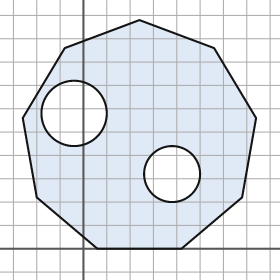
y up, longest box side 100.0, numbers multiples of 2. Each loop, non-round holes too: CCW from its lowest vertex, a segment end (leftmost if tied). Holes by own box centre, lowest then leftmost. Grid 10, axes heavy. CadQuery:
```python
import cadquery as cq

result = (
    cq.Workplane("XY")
    .moveTo(6.0, 0.0)
    .lineTo(42.0, 0.0)
    .lineTo(68.0, 22.0)
    .lineTo(74.0, 56.0)
    .lineTo(56.0, 86.0)
    .lineTo(24.0, 98.0)
    .lineTo(-8.0, 86.0)
    .lineTo(-26.0, 56.0)
    .lineTo(-20.0, 22.0)
    .close()
    .moveTo(38.0, 32.0)
    .circle(12.0)
    .moveTo(-4.0, 58.0)
    .circle(14.0)
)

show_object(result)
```